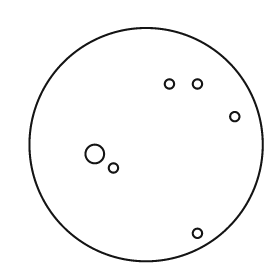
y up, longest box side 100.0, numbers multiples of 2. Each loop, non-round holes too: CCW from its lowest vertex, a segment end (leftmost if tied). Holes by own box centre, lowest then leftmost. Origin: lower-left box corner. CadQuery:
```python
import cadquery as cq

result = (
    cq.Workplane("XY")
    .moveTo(50.0, 50.0)
    .circle(50.0)
    .moveTo(72.0, 12.0)
    .circle(2.0)
    .moveTo(36.0, 40.0)
    .circle(2.0)
    .moveTo(28.0, 46.0)
    .circle(4.0)
    .moveTo(88.0, 62.0)
    .circle(2.0)
    .moveTo(60.0, 76.0)
    .circle(2.0)
    .moveTo(72.0, 76.0)
    .circle(2.0)
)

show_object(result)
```